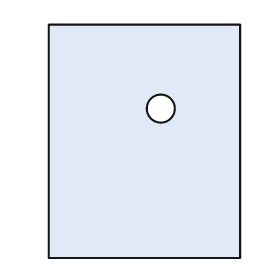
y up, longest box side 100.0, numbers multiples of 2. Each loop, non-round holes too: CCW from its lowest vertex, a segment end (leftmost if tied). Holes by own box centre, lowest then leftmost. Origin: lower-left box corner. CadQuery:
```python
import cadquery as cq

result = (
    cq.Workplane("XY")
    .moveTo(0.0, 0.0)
    .lineTo(82.0, 0.0)
    .lineTo(82.0, 100.0)
    .lineTo(0.0, 100.0)
    .close()
    .moveTo(48.0, 64.0)
    .circle(6.0)
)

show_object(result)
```